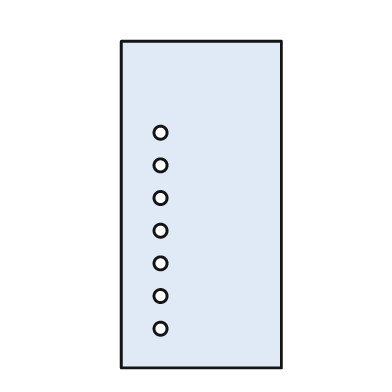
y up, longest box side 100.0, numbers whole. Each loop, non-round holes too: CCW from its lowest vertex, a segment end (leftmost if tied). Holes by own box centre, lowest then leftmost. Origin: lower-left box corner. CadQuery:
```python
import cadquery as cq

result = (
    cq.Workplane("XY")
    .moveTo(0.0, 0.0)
    .lineTo(49.0, 0.0)
    .lineTo(49.0, 100.0)
    .lineTo(0.0, 100.0)
    .close()
    .moveTo(12.0, 12.0)
    .circle(2.0)
    .moveTo(12.0, 22.0)
    .circle(2.0)
    .moveTo(12.0, 32.0)
    .circle(2.0)
    .moveTo(12.0, 42.0)
    .circle(2.0)
    .moveTo(12.0, 52.0)
    .circle(2.0)
    .moveTo(12.0, 62.0)
    .circle(2.0)
    .moveTo(12.0, 72.0)
    .circle(2.0)
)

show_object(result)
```